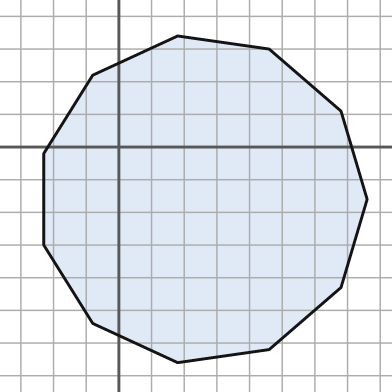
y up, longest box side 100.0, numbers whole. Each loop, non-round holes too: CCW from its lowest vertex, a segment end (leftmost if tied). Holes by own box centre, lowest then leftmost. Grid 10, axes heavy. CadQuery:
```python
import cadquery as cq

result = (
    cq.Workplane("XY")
    .moveTo(18.0, -66.0)
    .lineTo(46.0, -62.0)
    .lineTo(68.0, -43.0)
    .lineTo(76.0, -16.0)
    .lineTo(68.0, 11.0)
    .lineTo(46.0, 30.0)
    .lineTo(18.0, 34.0)
    .lineTo(-8.0, 22.0)
    .lineTo(-23.0, -2.0)
    .lineTo(-23.0, -30.0)
    .lineTo(-8.0, -54.0)
    .close()
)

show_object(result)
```